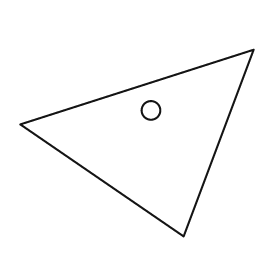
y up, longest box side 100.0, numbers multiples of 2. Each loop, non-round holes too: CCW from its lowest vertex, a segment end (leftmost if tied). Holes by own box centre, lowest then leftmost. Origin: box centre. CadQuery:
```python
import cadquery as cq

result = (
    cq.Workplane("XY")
    .moveTo(20.0, -40.0)
    .lineTo(50.0, 40.0)
    .lineTo(-50.0, 8.0)
    .close()
    .moveTo(6.0, 14.0)
    .circle(4.0)
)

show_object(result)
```